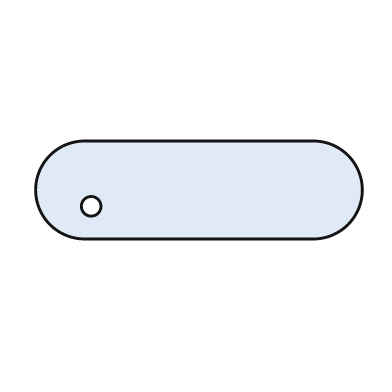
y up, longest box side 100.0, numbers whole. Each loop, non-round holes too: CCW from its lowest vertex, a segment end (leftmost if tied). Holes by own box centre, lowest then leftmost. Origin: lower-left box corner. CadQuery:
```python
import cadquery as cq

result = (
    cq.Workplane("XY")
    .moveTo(15.0, 0.0)
    .lineTo(85.0, 0.0)
    .threePointArc((100.0, 15.0), (85.0, 30.0))
    .lineTo(15.0, 30.0)
    .threePointArc((0.0, 15.0), (15.0, 0.0))
    .close()
    .moveTo(17.0, 10.0)
    .circle(3.0)
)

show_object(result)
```